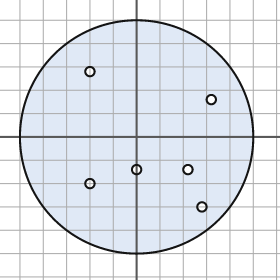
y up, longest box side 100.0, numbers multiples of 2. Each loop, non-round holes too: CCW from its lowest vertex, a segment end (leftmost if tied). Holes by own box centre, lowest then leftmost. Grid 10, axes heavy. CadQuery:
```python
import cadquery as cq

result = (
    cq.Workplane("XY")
    .moveTo(0.0, 0.0)
    .circle(50.0)
    .moveTo(28.0, -30.0)
    .circle(2.0)
    .moveTo(-20.0, -20.0)
    .circle(2.0)
    .moveTo(0.0, -14.0)
    .circle(2.0)
    .moveTo(22.0, -14.0)
    .circle(2.0)
    .moveTo(32.0, 16.0)
    .circle(2.0)
    .moveTo(-20.0, 28.0)
    .circle(2.0)
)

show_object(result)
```